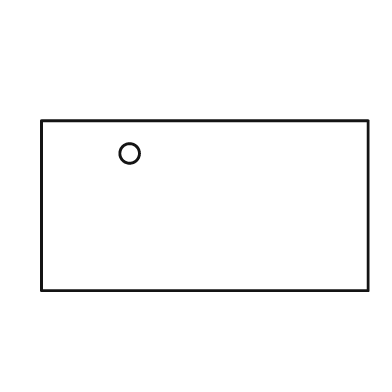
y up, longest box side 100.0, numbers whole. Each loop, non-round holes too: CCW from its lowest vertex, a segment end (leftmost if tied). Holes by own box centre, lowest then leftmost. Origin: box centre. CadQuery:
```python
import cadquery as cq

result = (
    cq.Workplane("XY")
    .moveTo(-50.0, -26.0)
    .lineTo(50.0, -26.0)
    .lineTo(50.0, 26.0)
    .lineTo(-50.0, 26.0)
    .close()
    .moveTo(-23.0, 16.0)
    .circle(3.0)
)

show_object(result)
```